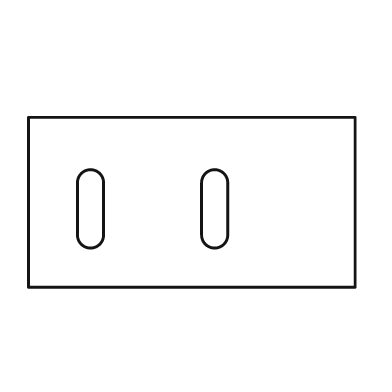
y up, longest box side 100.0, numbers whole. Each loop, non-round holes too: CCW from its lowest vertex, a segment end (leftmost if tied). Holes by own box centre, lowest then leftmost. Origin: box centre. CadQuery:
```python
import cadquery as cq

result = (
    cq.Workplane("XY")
    .moveTo(-50.0, -26.0)
    .lineTo(50.0, -26.0)
    .lineTo(50.0, 26.0)
    .lineTo(-50.0, 26.0)
    .close()
    .moveTo(-35.0, -10.0)
    .threePointArc((-31.0, -14.0), (-27.0, -10.0))
    .lineTo(-27.0, 6.0)
    .threePointArc((-31.0, 10.0), (-35.0, 6.0))
    .close()
    .moveTo(3.0, -10.0)
    .threePointArc((7.0, -14.0), (11.0, -10.0))
    .lineTo(11.0, 6.0)
    .threePointArc((7.0, 10.0), (3.0, 6.0))
    .close()
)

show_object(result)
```